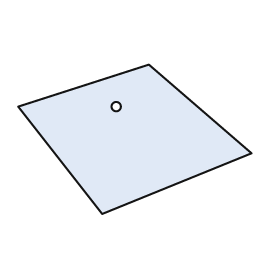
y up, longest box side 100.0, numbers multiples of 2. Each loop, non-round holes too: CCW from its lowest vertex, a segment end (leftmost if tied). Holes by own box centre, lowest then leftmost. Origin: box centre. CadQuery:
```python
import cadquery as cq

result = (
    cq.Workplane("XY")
    .moveTo(-14.0, -32.0)
    .lineTo(50.0, -6.0)
    .lineTo(6.0, 32.0)
    .lineTo(-50.0, 14.0)
    .close()
    .moveTo(-8.0, 14.0)
    .circle(2.0)
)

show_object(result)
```